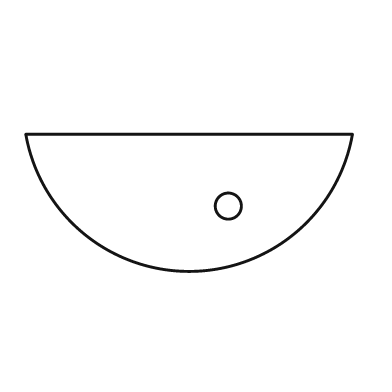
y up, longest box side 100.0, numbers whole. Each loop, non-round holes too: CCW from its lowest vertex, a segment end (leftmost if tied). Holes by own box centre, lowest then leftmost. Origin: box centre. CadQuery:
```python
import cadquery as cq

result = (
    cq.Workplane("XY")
    .moveTo(-50.0, 21.0)
    .threePointArc((0.0, -21.0), (50.0, 21.0))
    .close()
    .moveTo(12.0, -1.0)
    .circle(4.0)
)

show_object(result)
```